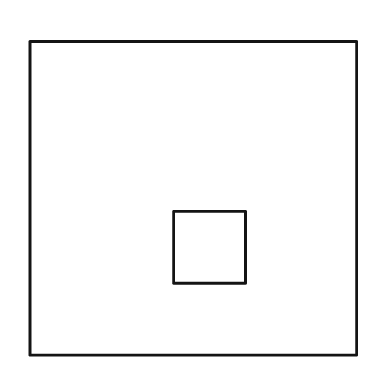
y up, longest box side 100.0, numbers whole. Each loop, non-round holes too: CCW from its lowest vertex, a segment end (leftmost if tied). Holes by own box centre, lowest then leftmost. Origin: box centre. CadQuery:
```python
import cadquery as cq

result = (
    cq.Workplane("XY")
    .moveTo(-50.0, -48.0)
    .lineTo(50.0, -48.0)
    .lineTo(50.0, 48.0)
    .lineTo(-50.0, 48.0)
    .close()
    .moveTo(-6.0, -26.0)
    .lineTo(16.0, -26.0)
    .lineTo(16.0, -4.0)
    .lineTo(-6.0, -4.0)
    .close()
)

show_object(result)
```